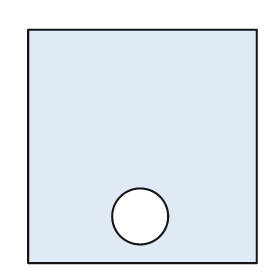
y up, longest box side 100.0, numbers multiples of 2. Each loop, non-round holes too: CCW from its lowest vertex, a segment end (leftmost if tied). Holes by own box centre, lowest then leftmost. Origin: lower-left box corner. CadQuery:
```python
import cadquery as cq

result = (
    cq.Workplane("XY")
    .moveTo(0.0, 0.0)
    .lineTo(98.0, 0.0)
    .lineTo(98.0, 100.0)
    .lineTo(0.0, 100.0)
    .close()
    .moveTo(48.0, 20.0)
    .circle(12.0)
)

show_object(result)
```